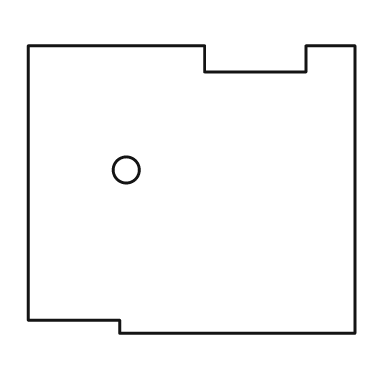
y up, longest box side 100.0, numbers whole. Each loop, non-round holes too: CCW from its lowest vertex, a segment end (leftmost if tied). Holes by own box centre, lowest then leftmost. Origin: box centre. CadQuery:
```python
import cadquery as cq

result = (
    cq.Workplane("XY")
    .moveTo(-22.0, -44.0)
    .lineTo(50.0, -44.0)
    .lineTo(50.0, 44.0)
    .lineTo(35.0, 44.0)
    .lineTo(35.0, 36.0)
    .lineTo(4.0, 36.0)
    .lineTo(4.0, 44.0)
    .lineTo(-50.0, 44.0)
    .lineTo(-50.0, -40.0)
    .lineTo(-22.0, -40.0)
    .close()
    .moveTo(-20.0, 6.0)
    .circle(4.0)
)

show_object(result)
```